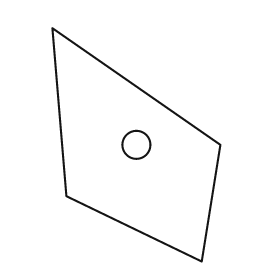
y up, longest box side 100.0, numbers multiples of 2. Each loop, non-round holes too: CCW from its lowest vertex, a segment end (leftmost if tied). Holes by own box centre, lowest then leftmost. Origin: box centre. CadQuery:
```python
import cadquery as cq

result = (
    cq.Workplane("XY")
    .moveTo(28.0, -50.0)
    .lineTo(36.0, 0.0)
    .lineTo(-36.0, 50.0)
    .lineTo(-30.0, -22.0)
    .close()
    .moveTo(0.0, 0.0)
    .circle(6.0)
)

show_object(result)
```